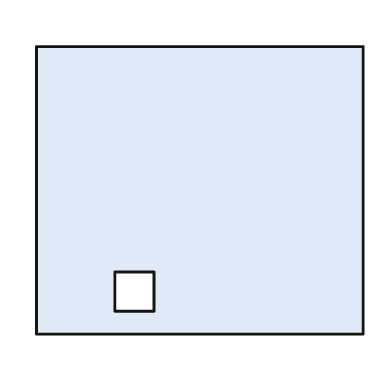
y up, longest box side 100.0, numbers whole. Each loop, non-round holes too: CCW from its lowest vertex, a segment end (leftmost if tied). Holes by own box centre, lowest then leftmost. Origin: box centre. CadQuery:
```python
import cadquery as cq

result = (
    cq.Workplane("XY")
    .moveTo(-50.0, -44.0)
    .lineTo(50.0, -44.0)
    .lineTo(50.0, 44.0)
    .lineTo(-50.0, 44.0)
    .close()
    .moveTo(-26.0, -37.0)
    .lineTo(-14.0, -37.0)
    .lineTo(-14.0, -25.0)
    .lineTo(-26.0, -25.0)
    .close()
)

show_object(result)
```